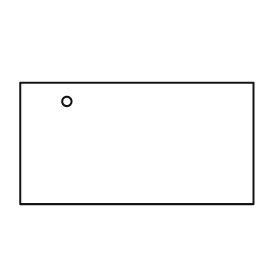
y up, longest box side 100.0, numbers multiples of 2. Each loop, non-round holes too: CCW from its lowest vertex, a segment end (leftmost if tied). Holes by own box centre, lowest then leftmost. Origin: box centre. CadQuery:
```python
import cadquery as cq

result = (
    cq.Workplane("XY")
    .moveTo(-50.0, -26.0)
    .lineTo(50.0, -26.0)
    .lineTo(50.0, 26.0)
    .lineTo(-50.0, 26.0)
    .close()
    .moveTo(-30.0, 18.0)
    .circle(2.0)
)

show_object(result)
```